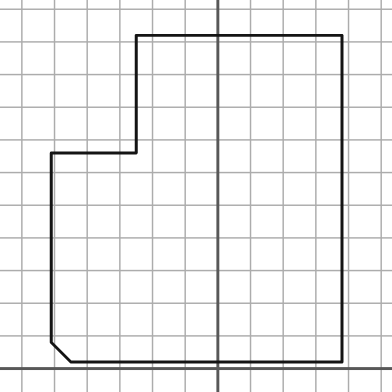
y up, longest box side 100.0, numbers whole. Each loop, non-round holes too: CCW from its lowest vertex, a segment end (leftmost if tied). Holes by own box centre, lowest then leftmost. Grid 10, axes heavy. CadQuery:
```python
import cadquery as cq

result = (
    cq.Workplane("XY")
    .moveTo(-45.0, 2.0)
    .lineTo(38.0, 2.0)
    .lineTo(38.0, 102.0)
    .lineTo(-25.0, 102.0)
    .lineTo(-25.0, 66.0)
    .lineTo(-51.0, 66.0)
    .lineTo(-51.0, 8.0)
    .close()
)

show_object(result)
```